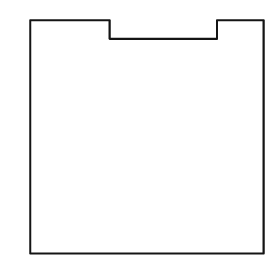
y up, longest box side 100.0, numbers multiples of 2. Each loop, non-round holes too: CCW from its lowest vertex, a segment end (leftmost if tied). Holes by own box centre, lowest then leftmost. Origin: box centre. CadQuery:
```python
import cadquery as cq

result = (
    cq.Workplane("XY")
    .moveTo(-50.0, -50.0)
    .lineTo(50.0, -50.0)
    .lineTo(50.0, 50.0)
    .lineTo(30.0, 50.0)
    .lineTo(30.0, 42.0)
    .lineTo(-16.0, 42.0)
    .lineTo(-16.0, 50.0)
    .lineTo(-50.0, 50.0)
    .close()
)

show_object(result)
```